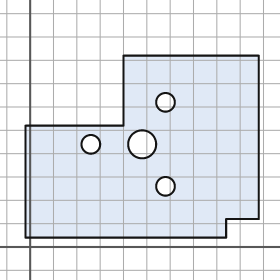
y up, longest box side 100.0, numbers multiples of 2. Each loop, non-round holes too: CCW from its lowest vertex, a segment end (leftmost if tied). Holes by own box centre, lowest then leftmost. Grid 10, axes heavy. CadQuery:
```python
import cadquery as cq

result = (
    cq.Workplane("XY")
    .moveTo(-2.0, 4.0)
    .lineTo(84.0, 4.0)
    .lineTo(84.0, 12.0)
    .lineTo(98.0, 12.0)
    .lineTo(98.0, 82.0)
    .lineTo(40.0, 82.0)
    .lineTo(40.0, 52.0)
    .lineTo(-2.0, 52.0)
    .close()
    .moveTo(58.0, 26.0)
    .circle(4.0)
    .moveTo(26.0, 44.0)
    .circle(4.0)
    .moveTo(48.0, 44.0)
    .circle(6.0)
    .moveTo(58.0, 62.0)
    .circle(4.0)
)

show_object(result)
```